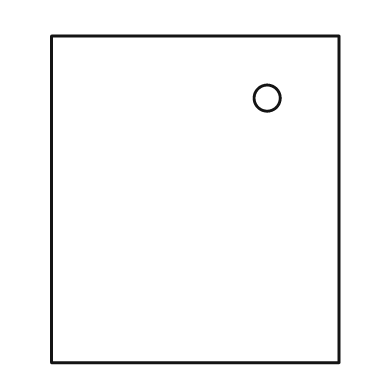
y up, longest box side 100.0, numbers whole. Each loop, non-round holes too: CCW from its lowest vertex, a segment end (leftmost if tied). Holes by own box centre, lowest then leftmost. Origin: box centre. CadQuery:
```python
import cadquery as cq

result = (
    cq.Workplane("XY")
    .moveTo(-44.0, -50.0)
    .lineTo(44.0, -50.0)
    .lineTo(44.0, 50.0)
    .lineTo(-44.0, 50.0)
    .close()
    .moveTo(22.0, 31.0)
    .circle(4.0)
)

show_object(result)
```